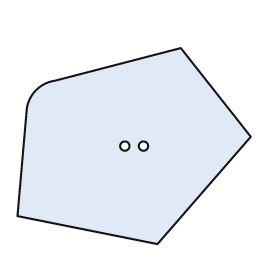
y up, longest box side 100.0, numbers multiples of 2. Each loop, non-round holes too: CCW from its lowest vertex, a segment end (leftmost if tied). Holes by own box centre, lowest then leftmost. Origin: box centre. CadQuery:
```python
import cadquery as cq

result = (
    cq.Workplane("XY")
    .moveTo(10.0, -42.0)
    .lineTo(50.0, 4.0)
    .lineTo(20.0, 42.0)
    .lineTo(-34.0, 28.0)
    .threePointArc((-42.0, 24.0), (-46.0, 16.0))
    .lineTo(-50.0, -30.0)
    .close()
    .moveTo(-4.0, 0.0)
    .circle(2.0)
    .moveTo(4.0, 0.0)
    .circle(2.0)
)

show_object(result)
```